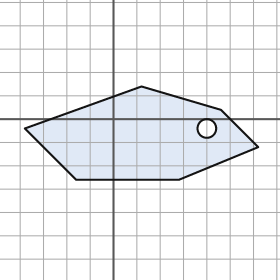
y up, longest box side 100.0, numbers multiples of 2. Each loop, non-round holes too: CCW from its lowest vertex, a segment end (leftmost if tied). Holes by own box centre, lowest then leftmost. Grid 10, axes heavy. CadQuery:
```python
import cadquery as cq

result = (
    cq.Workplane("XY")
    .moveTo(-16.0, -26.0)
    .lineTo(28.0, -26.0)
    .lineTo(62.0, -12.0)
    .lineTo(46.0, 4.0)
    .lineTo(12.0, 14.0)
    .lineTo(-38.0, -4.0)
    .close()
    .moveTo(40.0, -4.0)
    .circle(4.0)
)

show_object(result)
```